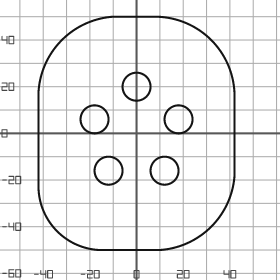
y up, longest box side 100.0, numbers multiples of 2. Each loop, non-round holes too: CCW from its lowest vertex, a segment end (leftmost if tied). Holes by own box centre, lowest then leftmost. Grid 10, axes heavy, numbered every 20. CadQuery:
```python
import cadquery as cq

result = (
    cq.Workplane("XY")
    .moveTo(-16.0, -50.0)
    .lineTo(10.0, -50.0)
    .threePointArc((32.0, -40.0), (42.0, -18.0))
    .lineTo(42.0, 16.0)
    .threePointArc((32.0, 40.0), (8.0, 50.0))
    .lineTo(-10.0, 50.0)
    .threePointArc((-32.0, 40.0), (-42.0, 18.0))
    .lineTo(-42.0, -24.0)
    .threePointArc((-34.0, -42.0), (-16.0, -50.0))
    .close()
    .moveTo(-12.0, -16.0)
    .circle(6.0)
    .moveTo(12.0, -16.0)
    .circle(6.0)
    .moveTo(-18.0, 6.0)
    .circle(6.0)
    .moveTo(18.0, 6.0)
    .circle(6.0)
    .moveTo(0.0, 20.0)
    .circle(6.0)
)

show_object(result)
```